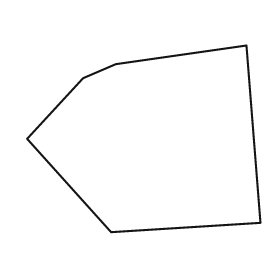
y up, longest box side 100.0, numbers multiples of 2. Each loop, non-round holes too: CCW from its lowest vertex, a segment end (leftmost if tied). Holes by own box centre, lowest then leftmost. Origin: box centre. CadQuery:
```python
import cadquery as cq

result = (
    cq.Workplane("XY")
    .moveTo(-14.0, -40.0)
    .lineTo(50.0, -36.0)
    .lineTo(44.0, 40.0)
    .lineTo(-12.0, 32.0)
    .lineTo(-26.0, 26.0)
    .lineTo(-50.0, 0.0)
    .close()
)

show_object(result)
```